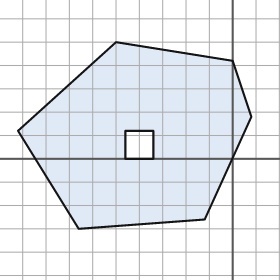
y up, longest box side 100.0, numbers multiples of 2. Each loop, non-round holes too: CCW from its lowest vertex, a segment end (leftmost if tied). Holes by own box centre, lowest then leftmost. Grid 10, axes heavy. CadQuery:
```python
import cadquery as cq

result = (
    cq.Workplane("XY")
    .moveTo(-66.0, -30.0)
    .lineTo(-12.0, -26.0)
    .lineTo(8.0, 18.0)
    .lineTo(0.0, 42.0)
    .lineTo(-50.0, 50.0)
    .lineTo(-92.0, 12.0)
    .close()
    .moveTo(-46.0, 0.0)
    .lineTo(-34.0, 0.0)
    .lineTo(-34.0, 12.0)
    .lineTo(-46.0, 12.0)
    .close()
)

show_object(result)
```